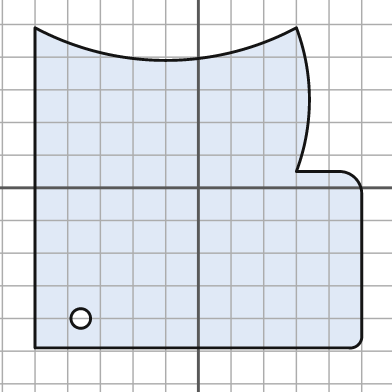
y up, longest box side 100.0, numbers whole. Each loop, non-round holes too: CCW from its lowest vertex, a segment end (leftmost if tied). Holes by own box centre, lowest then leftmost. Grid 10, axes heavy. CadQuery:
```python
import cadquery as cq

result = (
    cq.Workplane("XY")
    .moveTo(-50.0, -49.0)
    .lineTo(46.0, -49.0)
    .threePointArc((49.0, -48.0), (50.0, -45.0))
    .lineTo(50.0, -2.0)
    .threePointArc((48.0, 3.0), (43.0, 5.0))
    .lineTo(30.0, 5.0)
    .threePointArc((34.0, 27.0), (30.0, 49.0))
    .threePointArc((-10.0, 39.0), (-50.0, 49.0))
    .close()
    .moveTo(-36.0, -40.0)
    .circle(3.0)
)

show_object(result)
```